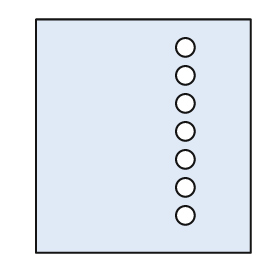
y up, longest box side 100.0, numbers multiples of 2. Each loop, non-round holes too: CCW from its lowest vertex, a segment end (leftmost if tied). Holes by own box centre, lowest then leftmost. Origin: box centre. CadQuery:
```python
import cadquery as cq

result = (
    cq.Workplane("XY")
    .moveTo(-46.0, -50.0)
    .lineTo(46.0, -50.0)
    .lineTo(46.0, 50.0)
    .lineTo(-46.0, 50.0)
    .close()
    .moveTo(18.0, -34.0)
    .circle(4.0)
    .moveTo(18.0, -22.0)
    .circle(4.0)
    .moveTo(18.0, -10.0)
    .circle(4.0)
    .moveTo(18.0, 2.0)
    .circle(4.0)
    .moveTo(18.0, 14.0)
    .circle(4.0)
    .moveTo(18.0, 26.0)
    .circle(4.0)
    .moveTo(18.0, 38.0)
    .circle(4.0)
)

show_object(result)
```